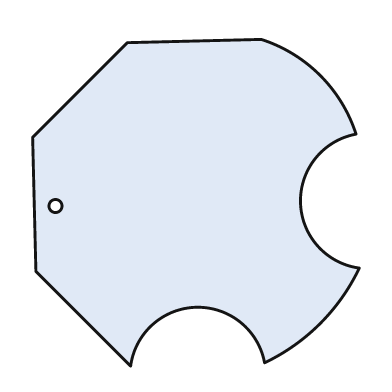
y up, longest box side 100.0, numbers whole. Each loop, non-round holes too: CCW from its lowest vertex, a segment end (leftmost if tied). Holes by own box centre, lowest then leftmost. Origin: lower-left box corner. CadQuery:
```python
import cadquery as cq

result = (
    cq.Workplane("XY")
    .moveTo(30.0, 0.0)
    .threePointArc((50.0, 18.0), (71.0, 1.0))
    .threePointArc((88.0, 13.0), (100.0, 30.0))
    .threePointArc((82.0, 50.0), (99.0, 71.0))
    .threePointArc((88.0, 89.0), (70.0, 100.0))
    .lineTo(29.0, 99.0)
    .lineTo(0.0, 70.0)
    .lineTo(1.0, 29.0)
    .close()
    .moveTo(7.0, 49.0)
    .circle(2.0)
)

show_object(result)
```